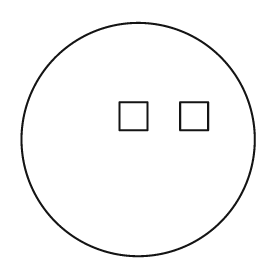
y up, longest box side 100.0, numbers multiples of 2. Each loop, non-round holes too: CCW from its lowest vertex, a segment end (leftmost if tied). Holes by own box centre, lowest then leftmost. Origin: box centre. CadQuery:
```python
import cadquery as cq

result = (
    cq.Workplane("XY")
    .moveTo(0.0, 0.0)
    .circle(50.0)
    .moveTo(-8.0, 4.0)
    .lineTo(4.0, 4.0)
    .lineTo(4.0, 16.0)
    .lineTo(-8.0, 16.0)
    .close()
    .moveTo(18.0, 4.0)
    .lineTo(30.0, 4.0)
    .lineTo(30.0, 16.0)
    .lineTo(18.0, 16.0)
    .close()
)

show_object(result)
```